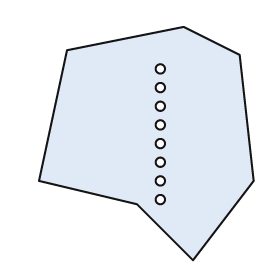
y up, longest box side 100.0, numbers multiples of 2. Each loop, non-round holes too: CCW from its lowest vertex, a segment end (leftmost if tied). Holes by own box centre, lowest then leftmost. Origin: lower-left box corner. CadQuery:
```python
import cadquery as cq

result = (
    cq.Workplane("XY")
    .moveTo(66.0, 0.0)
    .lineTo(92.0, 34.0)
    .lineTo(86.0, 88.0)
    .lineTo(62.0, 100.0)
    .lineTo(12.0, 90.0)
    .lineTo(0.0, 34.0)
    .lineTo(42.0, 24.0)
    .close()
    .moveTo(52.0, 26.0)
    .circle(2.0)
    .moveTo(52.0, 34.0)
    .circle(2.0)
    .moveTo(52.0, 42.0)
    .circle(2.0)
    .moveTo(52.0, 50.0)
    .circle(2.0)
    .moveTo(52.0, 58.0)
    .circle(2.0)
    .moveTo(52.0, 66.0)
    .circle(2.0)
    .moveTo(52.0, 74.0)
    .circle(2.0)
    .moveTo(52.0, 82.0)
    .circle(2.0)
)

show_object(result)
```